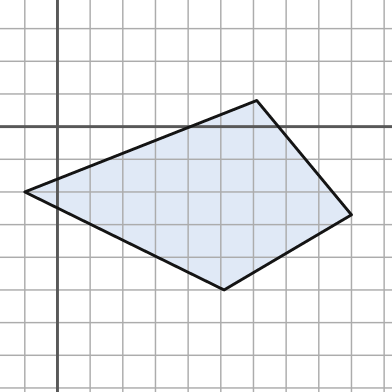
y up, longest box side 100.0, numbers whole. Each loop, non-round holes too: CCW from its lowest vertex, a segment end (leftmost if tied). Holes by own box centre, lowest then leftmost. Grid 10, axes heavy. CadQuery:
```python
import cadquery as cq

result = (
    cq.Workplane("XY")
    .moveTo(51.0, -50.0)
    .lineTo(90.0, -27.0)
    .lineTo(61.0, 8.0)
    .lineTo(-10.0, -20.0)
    .close()
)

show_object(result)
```